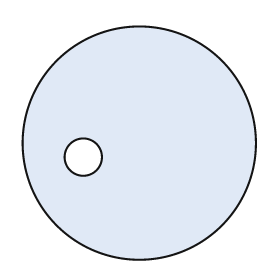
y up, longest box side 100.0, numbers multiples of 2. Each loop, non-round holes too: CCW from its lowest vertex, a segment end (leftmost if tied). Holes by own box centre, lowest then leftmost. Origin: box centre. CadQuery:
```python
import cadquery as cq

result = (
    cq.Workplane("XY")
    .moveTo(0.0, 0.0)
    .circle(50.0)
    .moveTo(-24.0, -6.0)
    .circle(8.0)
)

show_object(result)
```